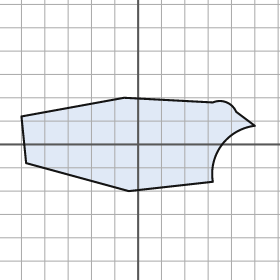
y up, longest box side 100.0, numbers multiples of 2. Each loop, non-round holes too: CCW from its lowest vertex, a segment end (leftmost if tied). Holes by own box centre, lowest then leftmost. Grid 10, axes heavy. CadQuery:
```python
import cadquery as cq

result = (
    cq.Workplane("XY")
    .moveTo(-4.0, -20.0)
    .lineTo(32.0, -16.0)
    .threePointArc((36.0, 0.0), (50.0, 8.0))
    .lineTo(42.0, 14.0)
    .threePointArc((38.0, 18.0), (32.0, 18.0))
    .lineTo(-6.0, 20.0)
    .lineTo(-50.0, 12.0)
    .lineTo(-48.0, -8.0)
    .close()
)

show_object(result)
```